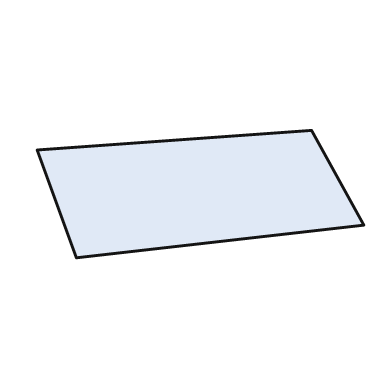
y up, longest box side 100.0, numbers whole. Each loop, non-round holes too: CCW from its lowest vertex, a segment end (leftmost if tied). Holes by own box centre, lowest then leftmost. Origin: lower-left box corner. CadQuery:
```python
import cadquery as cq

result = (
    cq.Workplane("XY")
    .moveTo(12.0, 0.0)
    .lineTo(100.0, 10.0)
    .lineTo(84.0, 39.0)
    .lineTo(0.0, 33.0)
    .close()
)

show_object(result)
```